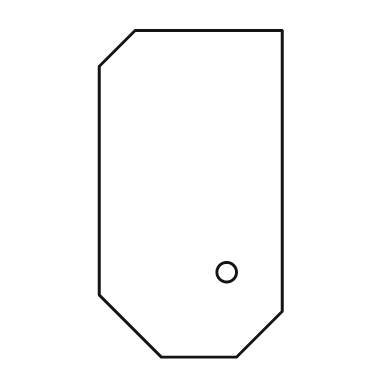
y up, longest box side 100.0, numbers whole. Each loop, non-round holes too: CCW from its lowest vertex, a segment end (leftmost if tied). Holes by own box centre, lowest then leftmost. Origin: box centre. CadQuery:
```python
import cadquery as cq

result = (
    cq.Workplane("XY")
    .moveTo(-9.0, -50.0)
    .lineTo(14.0, -50.0)
    .lineTo(28.0, -36.0)
    .lineTo(28.0, 50.0)
    .lineTo(-17.0, 50.0)
    .lineTo(-28.0, 39.0)
    .lineTo(-28.0, -31.0)
    .close()
    .moveTo(11.0, -24.0)
    .circle(3.0)
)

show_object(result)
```